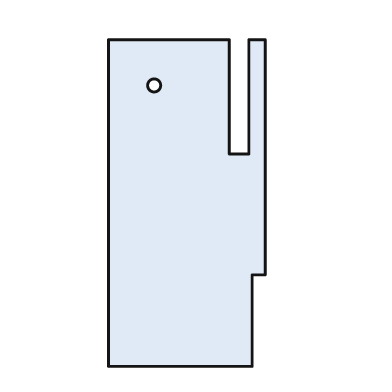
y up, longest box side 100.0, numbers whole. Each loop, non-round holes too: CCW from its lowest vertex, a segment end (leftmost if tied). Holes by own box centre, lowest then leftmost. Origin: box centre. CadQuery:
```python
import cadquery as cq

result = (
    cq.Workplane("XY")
    .moveTo(-24.0, -50.0)
    .lineTo(20.0, -50.0)
    .lineTo(20.0, -22.0)
    .lineTo(24.0, -22.0)
    .lineTo(24.0, 50.0)
    .lineTo(19.0, 50.0)
    .lineTo(19.0, 15.0)
    .lineTo(13.0, 15.0)
    .lineTo(13.0, 50.0)
    .lineTo(-24.0, 50.0)
    .close()
    .moveTo(-10.0, 36.0)
    .circle(2.0)
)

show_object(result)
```